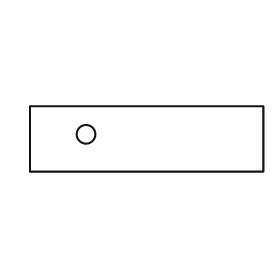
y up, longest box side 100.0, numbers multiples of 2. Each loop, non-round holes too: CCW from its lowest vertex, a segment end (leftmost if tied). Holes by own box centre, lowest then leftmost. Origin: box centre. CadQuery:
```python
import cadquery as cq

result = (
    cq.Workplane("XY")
    .moveTo(-50.0, -14.0)
    .lineTo(50.0, -14.0)
    .lineTo(50.0, 14.0)
    .lineTo(-50.0, 14.0)
    .close()
    .moveTo(-26.0, 2.0)
    .circle(4.0)
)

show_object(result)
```